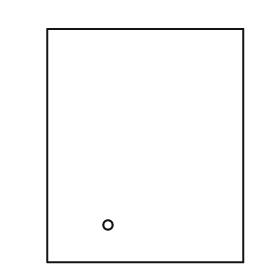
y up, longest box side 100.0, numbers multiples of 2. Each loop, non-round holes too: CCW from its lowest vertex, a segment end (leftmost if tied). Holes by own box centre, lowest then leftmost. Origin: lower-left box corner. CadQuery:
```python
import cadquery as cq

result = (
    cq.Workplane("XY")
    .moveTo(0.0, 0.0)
    .lineTo(84.0, 0.0)
    .lineTo(84.0, 100.0)
    .lineTo(0.0, 100.0)
    .close()
    .moveTo(26.0, 16.0)
    .circle(2.0)
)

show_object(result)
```